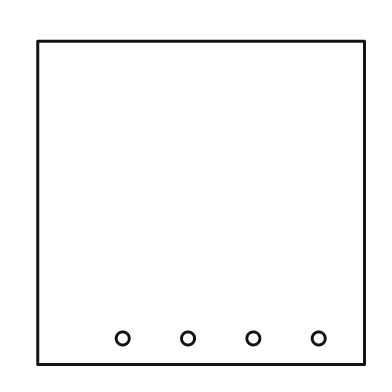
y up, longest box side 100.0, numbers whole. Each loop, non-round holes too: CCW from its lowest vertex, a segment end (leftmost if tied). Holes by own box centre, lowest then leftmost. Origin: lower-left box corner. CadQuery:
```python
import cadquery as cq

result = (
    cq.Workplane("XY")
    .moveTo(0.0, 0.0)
    .lineTo(100.0, 0.0)
    .lineTo(100.0, 99.0)
    .lineTo(0.0, 99.0)
    .close()
    .moveTo(26.0, 8.0)
    .circle(2.0)
    .moveTo(46.0, 8.0)
    .circle(2.0)
    .moveTo(66.0, 8.0)
    .circle(2.0)
    .moveTo(86.0, 8.0)
    .circle(2.0)
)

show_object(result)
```